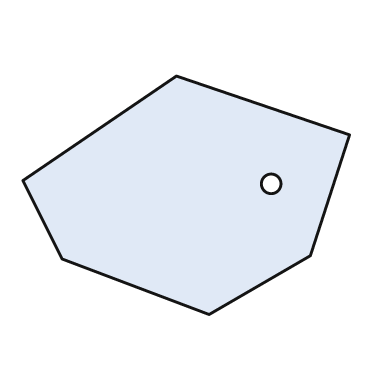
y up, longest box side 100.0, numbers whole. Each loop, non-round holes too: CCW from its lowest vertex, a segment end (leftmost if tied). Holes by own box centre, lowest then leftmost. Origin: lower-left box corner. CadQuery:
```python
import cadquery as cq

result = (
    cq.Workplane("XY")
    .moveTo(57.0, 0.0)
    .lineTo(88.0, 18.0)
    .lineTo(100.0, 55.0)
    .lineTo(47.0, 73.0)
    .lineTo(0.0, 41.0)
    .lineTo(12.0, 17.0)
    .close()
    .moveTo(76.0, 40.0)
    .circle(3.0)
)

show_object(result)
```